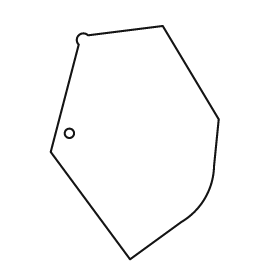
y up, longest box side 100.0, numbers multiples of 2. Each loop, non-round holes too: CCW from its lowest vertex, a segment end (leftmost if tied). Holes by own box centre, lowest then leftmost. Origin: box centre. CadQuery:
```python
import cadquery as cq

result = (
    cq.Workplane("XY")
    .moveTo(-2.0, -50.0)
    .lineTo(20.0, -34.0)
    .threePointArc((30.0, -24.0), (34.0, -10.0))
    .lineTo(36.0, 10.0)
    .lineTo(12.0, 50.0)
    .lineTo(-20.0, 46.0)
    .threePointArc((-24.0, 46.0), (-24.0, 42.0))
    .lineTo(-36.0, -4.0)
    .close()
    .moveTo(-28.0, 4.0)
    .circle(2.0)
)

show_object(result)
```